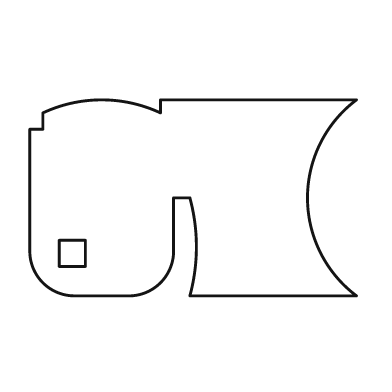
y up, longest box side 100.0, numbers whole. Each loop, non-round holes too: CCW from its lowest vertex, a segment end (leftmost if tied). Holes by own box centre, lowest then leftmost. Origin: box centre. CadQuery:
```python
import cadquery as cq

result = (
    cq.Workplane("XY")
    .moveTo(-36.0, -30.0)
    .lineTo(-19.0, -30.0)
    .threePointArc((-10.0, -26.0), (-6.0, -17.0))
    .lineTo(-6.0, 0.0)
    .lineTo(-1.0, 0.0)
    .threePointArc((1.0, -15.0), (-1.0, -30.0))
    .lineTo(50.0, -30.0)
    .threePointArc((35.0, 0.0), (50.0, 30.0))
    .lineTo(-10.0, 30.0)
    .lineTo(-10.0, 26.0)
    .threePointArc((-28.0, 30.0), (-46.0, 26.0))
    .lineTo(-46.0, 21.0)
    .lineTo(-50.0, 21.0)
    .lineTo(-50.0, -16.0)
    .threePointArc((-46.0, -26.0), (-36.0, -30.0))
    .close()
    .moveTo(-41.0, -21.0)
    .lineTo(-33.0, -21.0)
    .lineTo(-33.0, -13.0)
    .lineTo(-41.0, -13.0)
    .close()
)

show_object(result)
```